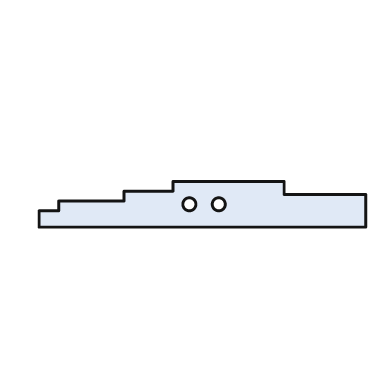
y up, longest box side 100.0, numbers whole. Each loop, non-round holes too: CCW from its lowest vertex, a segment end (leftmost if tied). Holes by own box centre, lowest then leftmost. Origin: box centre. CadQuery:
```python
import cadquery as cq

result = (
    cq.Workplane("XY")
    .moveTo(-50.0, -7.0)
    .lineTo(50.0, -7.0)
    .lineTo(50.0, 3.0)
    .lineTo(25.0, 3.0)
    .lineTo(25.0, 7.0)
    .lineTo(-9.0, 7.0)
    .lineTo(-9.0, 4.0)
    .lineTo(-24.0, 4.0)
    .lineTo(-24.0, 1.0)
    .lineTo(-44.0, 1.0)
    .lineTo(-44.0, -2.0)
    .lineTo(-50.0, -2.0)
    .close()
    .moveTo(-4.0, 0.0)
    .circle(2.0)
    .moveTo(5.0, 0.0)
    .circle(2.0)
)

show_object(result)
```